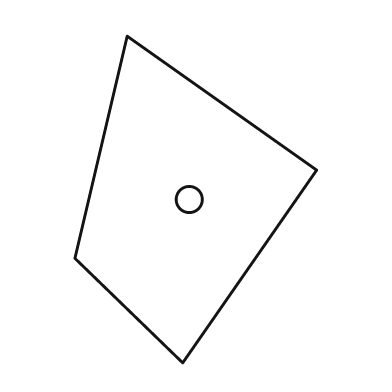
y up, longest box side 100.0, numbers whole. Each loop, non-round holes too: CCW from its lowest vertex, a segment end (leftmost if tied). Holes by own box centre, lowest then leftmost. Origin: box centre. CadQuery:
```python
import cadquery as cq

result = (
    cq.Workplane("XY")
    .moveTo(-4.0, -50.0)
    .lineTo(37.0, 9.0)
    .lineTo(-21.0, 50.0)
    .lineTo(-37.0, -18.0)
    .close()
    .moveTo(-2.0, 0.0)
    .circle(4.0)
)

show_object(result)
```